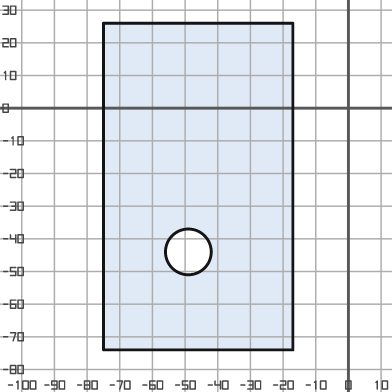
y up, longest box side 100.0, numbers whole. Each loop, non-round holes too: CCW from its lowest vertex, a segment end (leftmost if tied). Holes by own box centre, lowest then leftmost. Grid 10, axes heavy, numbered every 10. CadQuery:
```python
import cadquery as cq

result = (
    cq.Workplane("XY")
    .moveTo(-75.0, -74.0)
    .lineTo(-17.0, -74.0)
    .lineTo(-17.0, 26.0)
    .lineTo(-75.0, 26.0)
    .close()
    .moveTo(-49.0, -44.0)
    .circle(7.0)
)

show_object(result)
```